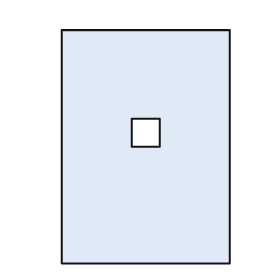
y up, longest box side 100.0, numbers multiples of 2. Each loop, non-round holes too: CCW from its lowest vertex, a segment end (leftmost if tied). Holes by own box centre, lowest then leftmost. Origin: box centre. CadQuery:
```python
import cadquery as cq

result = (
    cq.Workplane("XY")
    .moveTo(-36.0, -50.0)
    .lineTo(36.0, -50.0)
    .lineTo(36.0, 50.0)
    .lineTo(-36.0, 50.0)
    .close()
    .moveTo(-6.0, 0.0)
    .lineTo(6.0, 0.0)
    .lineTo(6.0, 12.0)
    .lineTo(-6.0, 12.0)
    .close()
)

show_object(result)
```